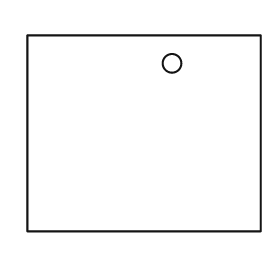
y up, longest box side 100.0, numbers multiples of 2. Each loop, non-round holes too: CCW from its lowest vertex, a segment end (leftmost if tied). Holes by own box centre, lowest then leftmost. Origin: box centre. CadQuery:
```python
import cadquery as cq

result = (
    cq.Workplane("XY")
    .moveTo(-50.0, -42.0)
    .lineTo(50.0, -42.0)
    .lineTo(50.0, 42.0)
    .lineTo(-50.0, 42.0)
    .close()
    .moveTo(12.0, 30.0)
    .circle(4.0)
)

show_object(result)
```